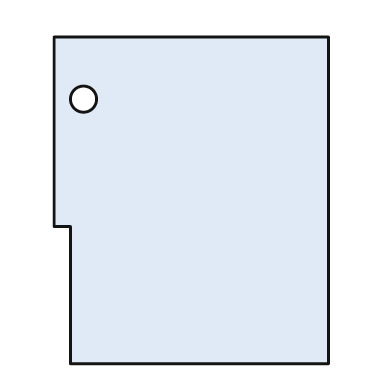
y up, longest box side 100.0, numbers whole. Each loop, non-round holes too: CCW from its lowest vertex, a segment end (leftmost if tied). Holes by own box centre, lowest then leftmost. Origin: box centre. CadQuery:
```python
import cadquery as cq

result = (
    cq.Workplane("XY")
    .moveTo(-37.0, -50.0)
    .lineTo(42.0, -50.0)
    .lineTo(42.0, 50.0)
    .lineTo(-42.0, 50.0)
    .lineTo(-42.0, -8.0)
    .lineTo(-37.0, -8.0)
    .close()
    .moveTo(-33.0, 31.0)
    .circle(4.0)
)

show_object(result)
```